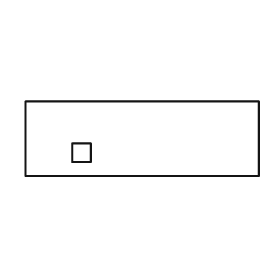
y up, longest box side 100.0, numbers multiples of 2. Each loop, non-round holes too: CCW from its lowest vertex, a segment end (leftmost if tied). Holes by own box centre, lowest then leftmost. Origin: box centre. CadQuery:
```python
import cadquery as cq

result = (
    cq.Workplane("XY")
    .moveTo(-50.0, -16.0)
    .lineTo(50.0, -16.0)
    .lineTo(50.0, 16.0)
    .lineTo(-50.0, 16.0)
    .close()
    .moveTo(-30.0, -10.0)
    .lineTo(-22.0, -10.0)
    .lineTo(-22.0, -2.0)
    .lineTo(-30.0, -2.0)
    .close()
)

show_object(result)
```